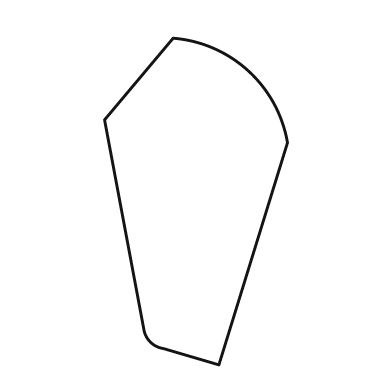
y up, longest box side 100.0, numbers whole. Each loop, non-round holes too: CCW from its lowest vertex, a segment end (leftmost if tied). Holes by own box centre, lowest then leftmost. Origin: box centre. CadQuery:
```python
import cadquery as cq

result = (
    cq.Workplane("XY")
    .moveTo(7.0, -50.0)
    .lineTo(28.0, 18.0)
    .threePointArc((16.0, 40.0), (-7.0, 50.0))
    .lineTo(-28.0, 25.0)
    .lineTo(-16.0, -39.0)
    .threePointArc((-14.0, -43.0), (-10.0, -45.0))
    .close()
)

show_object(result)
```